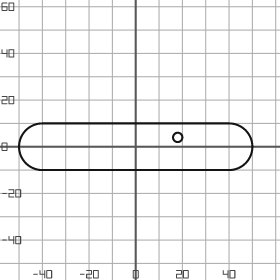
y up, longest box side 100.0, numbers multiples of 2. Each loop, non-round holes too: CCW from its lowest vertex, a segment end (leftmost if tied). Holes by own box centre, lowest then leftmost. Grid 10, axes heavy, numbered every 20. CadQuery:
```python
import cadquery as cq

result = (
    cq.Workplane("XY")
    .moveTo(-40.0, -10.0)
    .lineTo(40.0, -10.0)
    .threePointArc((50.0, 0.0), (40.0, 10.0))
    .lineTo(-40.0, 10.0)
    .threePointArc((-50.0, 0.0), (-40.0, -10.0))
    .close()
    .moveTo(18.0, 4.0)
    .circle(2.0)
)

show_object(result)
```